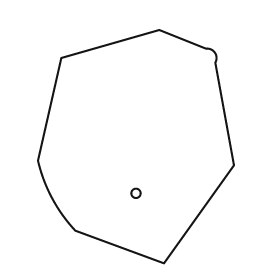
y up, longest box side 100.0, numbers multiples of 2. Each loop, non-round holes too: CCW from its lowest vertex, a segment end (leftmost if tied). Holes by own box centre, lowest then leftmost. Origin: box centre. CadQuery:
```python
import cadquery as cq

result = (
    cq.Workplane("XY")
    .moveTo(12.0, -50.0)
    .lineTo(42.0, -8.0)
    .lineTo(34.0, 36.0)
    .threePointArc((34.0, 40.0), (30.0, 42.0))
    .lineTo(10.0, 50.0)
    .lineTo(-32.0, 38.0)
    .lineTo(-42.0, -6.0)
    .threePointArc((-36.0, -22.0), (-26.0, -36.0))
    .close()
    .moveTo(0.0, -20.0)
    .circle(2.0)
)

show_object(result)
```